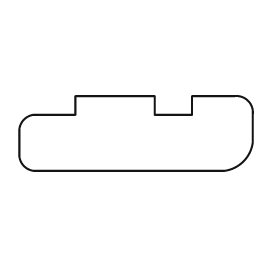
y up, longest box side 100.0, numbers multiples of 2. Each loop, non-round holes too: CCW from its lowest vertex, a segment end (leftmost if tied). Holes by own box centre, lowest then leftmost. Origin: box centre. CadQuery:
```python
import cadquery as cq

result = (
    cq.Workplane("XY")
    .moveTo(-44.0, -16.0)
    .lineTo(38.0, -16.0)
    .threePointArc((46.0, -12.0), (50.0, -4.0))
    .lineTo(50.0, 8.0)
    .threePointArc((48.0, 14.0), (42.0, 16.0))
    .lineTo(24.0, 16.0)
    .lineTo(24.0, 8.0)
    .lineTo(8.0, 8.0)
    .lineTo(8.0, 16.0)
    .lineTo(-26.0, 16.0)
    .lineTo(-26.0, 8.0)
    .lineTo(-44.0, 8.0)
    .threePointArc((-48.0, 6.0), (-50.0, 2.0))
    .lineTo(-50.0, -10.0)
    .threePointArc((-48.0, -14.0), (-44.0, -16.0))
    .close()
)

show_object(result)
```